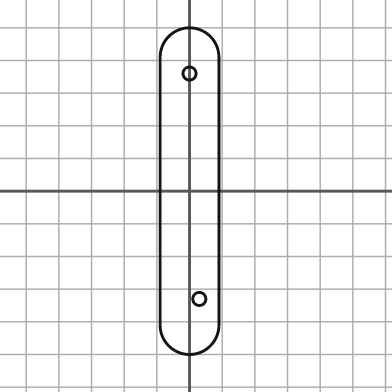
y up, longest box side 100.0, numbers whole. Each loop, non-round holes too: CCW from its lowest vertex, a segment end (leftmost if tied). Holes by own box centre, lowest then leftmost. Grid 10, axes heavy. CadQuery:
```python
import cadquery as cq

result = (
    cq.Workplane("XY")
    .moveTo(-9.0, -41.0)
    .threePointArc((0.0, -50.0), (9.0, -41.0))
    .lineTo(9.0, 41.0)
    .threePointArc((0.0, 50.0), (-9.0, 41.0))
    .close()
    .moveTo(3.0, -33.0)
    .circle(2.0)
    .moveTo(0.0, 36.0)
    .circle(2.0)
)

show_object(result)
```